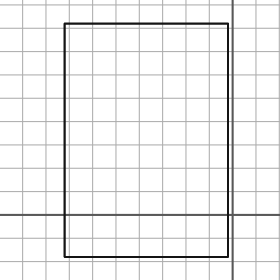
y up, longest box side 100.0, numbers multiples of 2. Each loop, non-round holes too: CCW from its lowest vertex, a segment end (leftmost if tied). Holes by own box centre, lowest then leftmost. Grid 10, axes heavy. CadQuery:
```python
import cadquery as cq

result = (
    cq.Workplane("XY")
    .moveTo(-72.0, -18.0)
    .lineTo(-2.0, -18.0)
    .lineTo(-2.0, 82.0)
    .lineTo(-72.0, 82.0)
    .close()
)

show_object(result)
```